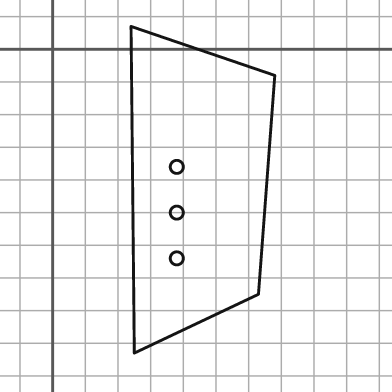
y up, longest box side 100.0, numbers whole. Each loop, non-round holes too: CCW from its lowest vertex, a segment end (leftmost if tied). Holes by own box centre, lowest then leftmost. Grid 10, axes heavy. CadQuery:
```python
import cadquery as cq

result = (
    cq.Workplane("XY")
    .moveTo(25.0, -93.0)
    .lineTo(63.0, -75.0)
    .lineTo(68.0, -8.0)
    .lineTo(24.0, 7.0)
    .close()
    .moveTo(38.0, -64.0)
    .circle(2.0)
    .moveTo(38.0, -50.0)
    .circle(2.0)
    .moveTo(38.0, -36.0)
    .circle(2.0)
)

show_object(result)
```